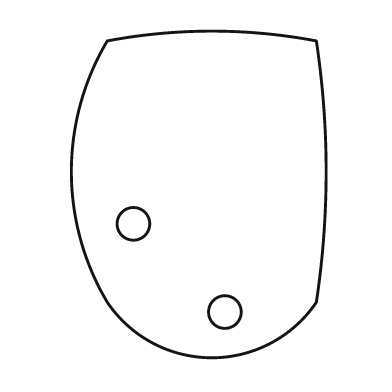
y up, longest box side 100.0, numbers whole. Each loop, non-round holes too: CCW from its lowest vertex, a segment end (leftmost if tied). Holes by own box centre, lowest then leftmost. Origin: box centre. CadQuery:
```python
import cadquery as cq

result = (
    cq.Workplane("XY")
    .moveTo(-28.0, -33.0)
    .threePointArc((4.0, -50.0), (36.0, -33.0))
    .threePointArc((39.0, 7.0), (36.0, 47.0))
    .threePointArc((4.0, 50.0), (-28.0, 47.0))
    .threePointArc((-39.0, 7.0), (-28.0, -33.0))
    .close()
    .moveTo(8.0, -36.0)
    .circle(5.0)
    .moveTo(-20.0, -9.0)
    .circle(5.0)
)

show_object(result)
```